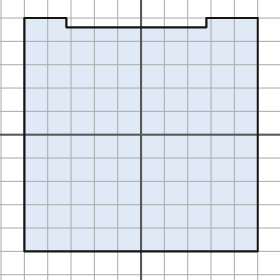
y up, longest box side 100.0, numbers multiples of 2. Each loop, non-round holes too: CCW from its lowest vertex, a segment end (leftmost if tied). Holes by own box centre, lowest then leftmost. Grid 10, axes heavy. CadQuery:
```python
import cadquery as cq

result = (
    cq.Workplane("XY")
    .moveTo(-50.0, -50.0)
    .lineTo(50.0, -50.0)
    .lineTo(50.0, 50.0)
    .lineTo(28.0, 50.0)
    .lineTo(28.0, 46.0)
    .lineTo(-32.0, 46.0)
    .lineTo(-32.0, 50.0)
    .lineTo(-50.0, 50.0)
    .close()
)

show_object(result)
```